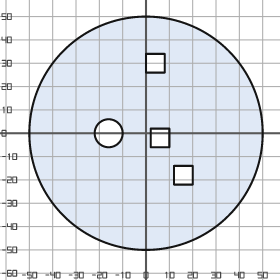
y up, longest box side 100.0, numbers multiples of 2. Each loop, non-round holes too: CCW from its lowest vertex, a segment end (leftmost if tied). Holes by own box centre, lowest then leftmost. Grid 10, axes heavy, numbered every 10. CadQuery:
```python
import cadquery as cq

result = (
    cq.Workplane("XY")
    .moveTo(0.0, 0.0)
    .circle(50.0)
    .moveTo(12.0, -22.0)
    .lineTo(20.0, -22.0)
    .lineTo(20.0, -14.0)
    .lineTo(12.0, -14.0)
    .close()
    .moveTo(2.0, -6.0)
    .lineTo(10.0, -6.0)
    .lineTo(10.0, 2.0)
    .lineTo(2.0, 2.0)
    .close()
    .moveTo(-16.0, 0.0)
    .circle(6.0)
    .moveTo(0.0, 26.0)
    .lineTo(8.0, 26.0)
    .lineTo(8.0, 34.0)
    .lineTo(0.0, 34.0)
    .close()
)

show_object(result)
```